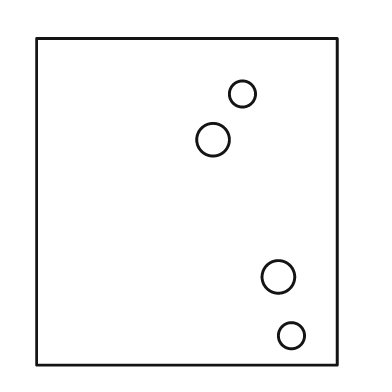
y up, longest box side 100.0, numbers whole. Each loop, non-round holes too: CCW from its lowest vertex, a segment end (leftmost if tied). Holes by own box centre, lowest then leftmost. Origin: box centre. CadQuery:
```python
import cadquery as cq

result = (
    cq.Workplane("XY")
    .moveTo(-46.0, -50.0)
    .lineTo(46.0, -50.0)
    .lineTo(46.0, 50.0)
    .lineTo(-46.0, 50.0)
    .close()
    .moveTo(32.0, -41.0)
    .circle(4.0)
    .moveTo(28.0, -23.0)
    .circle(5.0)
    .moveTo(8.0, 19.0)
    .circle(5.0)
    .moveTo(17.0, 33.0)
    .circle(4.0)
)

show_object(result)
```